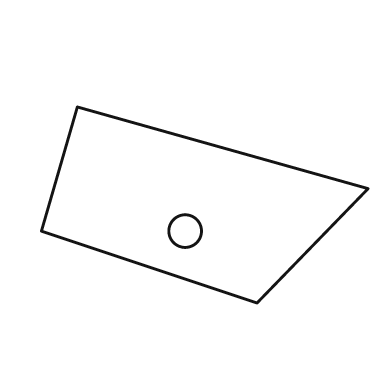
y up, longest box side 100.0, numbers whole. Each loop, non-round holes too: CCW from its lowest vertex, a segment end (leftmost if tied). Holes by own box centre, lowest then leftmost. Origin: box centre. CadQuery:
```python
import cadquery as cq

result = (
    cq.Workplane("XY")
    .moveTo(16.0, -30.0)
    .lineTo(50.0, 5.0)
    .lineTo(-39.0, 30.0)
    .lineTo(-50.0, -8.0)
    .close()
    .moveTo(-6.0, -8.0)
    .circle(5.0)
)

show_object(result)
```